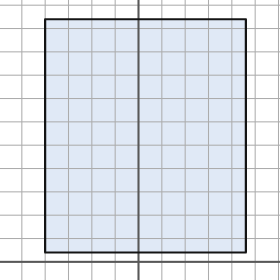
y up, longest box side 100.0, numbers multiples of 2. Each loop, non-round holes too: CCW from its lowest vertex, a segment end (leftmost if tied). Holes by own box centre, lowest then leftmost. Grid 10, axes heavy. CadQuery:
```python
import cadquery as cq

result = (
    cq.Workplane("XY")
    .moveTo(-40.0, 4.0)
    .lineTo(46.0, 4.0)
    .lineTo(46.0, 104.0)
    .lineTo(-40.0, 104.0)
    .close()
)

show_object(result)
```